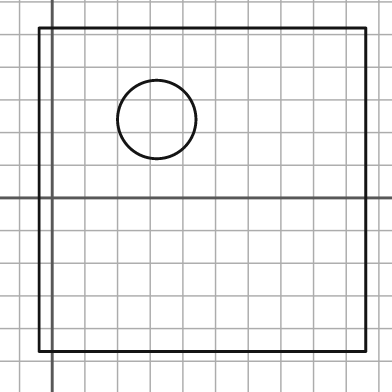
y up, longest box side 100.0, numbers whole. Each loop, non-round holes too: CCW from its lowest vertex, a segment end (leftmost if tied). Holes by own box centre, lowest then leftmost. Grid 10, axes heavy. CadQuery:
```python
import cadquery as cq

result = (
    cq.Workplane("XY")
    .moveTo(-4.0, -47.0)
    .lineTo(96.0, -47.0)
    .lineTo(96.0, 52.0)
    .lineTo(-4.0, 52.0)
    .close()
    .moveTo(32.0, 24.0)
    .circle(12.0)
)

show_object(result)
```